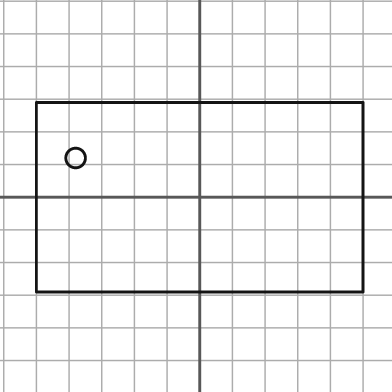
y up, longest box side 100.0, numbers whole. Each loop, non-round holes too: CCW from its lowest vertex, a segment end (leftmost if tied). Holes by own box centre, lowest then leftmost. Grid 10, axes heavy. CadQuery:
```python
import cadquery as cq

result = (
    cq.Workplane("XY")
    .moveTo(-50.0, -29.0)
    .lineTo(50.0, -29.0)
    .lineTo(50.0, 29.0)
    .lineTo(-50.0, 29.0)
    .close()
    .moveTo(-38.0, 12.0)
    .circle(3.0)
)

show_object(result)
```